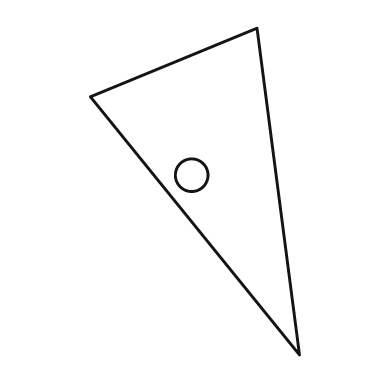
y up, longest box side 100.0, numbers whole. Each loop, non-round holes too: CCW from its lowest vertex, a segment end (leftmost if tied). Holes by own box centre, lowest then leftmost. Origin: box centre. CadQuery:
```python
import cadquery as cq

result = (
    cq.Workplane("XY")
    .moveTo(32.0, -50.0)
    .lineTo(19.0, 50.0)
    .lineTo(-32.0, 29.0)
    .close()
    .moveTo(-1.0, 5.0)
    .circle(5.0)
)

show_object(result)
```